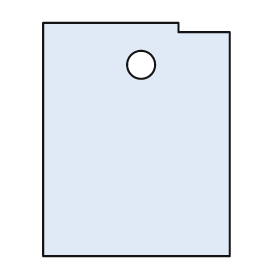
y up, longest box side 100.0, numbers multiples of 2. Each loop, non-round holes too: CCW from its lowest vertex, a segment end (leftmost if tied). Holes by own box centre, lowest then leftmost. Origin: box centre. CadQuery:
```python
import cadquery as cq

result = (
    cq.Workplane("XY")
    .moveTo(-40.0, -50.0)
    .lineTo(40.0, -50.0)
    .lineTo(40.0, 46.0)
    .lineTo(18.0, 46.0)
    .lineTo(18.0, 50.0)
    .lineTo(-40.0, 50.0)
    .close()
    .moveTo(2.0, 32.0)
    .circle(6.0)
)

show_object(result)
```